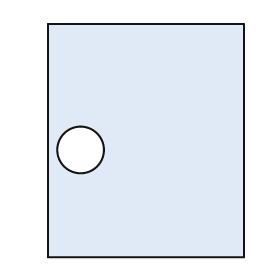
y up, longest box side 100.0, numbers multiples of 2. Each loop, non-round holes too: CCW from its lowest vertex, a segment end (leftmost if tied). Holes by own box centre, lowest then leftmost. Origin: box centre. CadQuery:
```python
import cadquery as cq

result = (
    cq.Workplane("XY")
    .moveTo(-42.0, -50.0)
    .lineTo(42.0, -50.0)
    .lineTo(42.0, 50.0)
    .lineTo(-42.0, 50.0)
    .close()
    .moveTo(-28.0, -4.0)
    .circle(10.0)
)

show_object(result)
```